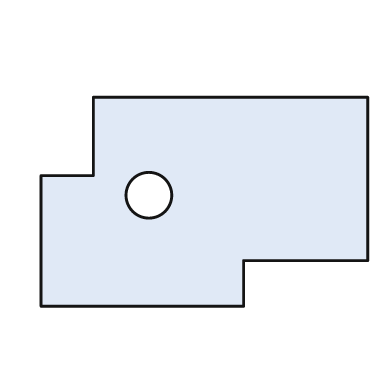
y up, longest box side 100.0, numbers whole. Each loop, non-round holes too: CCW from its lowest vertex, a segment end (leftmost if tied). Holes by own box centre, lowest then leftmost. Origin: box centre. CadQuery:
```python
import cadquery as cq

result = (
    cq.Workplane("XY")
    .moveTo(-50.0, -32.0)
    .lineTo(12.0, -32.0)
    .lineTo(12.0, -18.0)
    .lineTo(50.0, -18.0)
    .lineTo(50.0, 32.0)
    .lineTo(-34.0, 32.0)
    .lineTo(-34.0, 8.0)
    .lineTo(-50.0, 8.0)
    .close()
    .moveTo(-17.0, 2.0)
    .circle(7.0)
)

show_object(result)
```